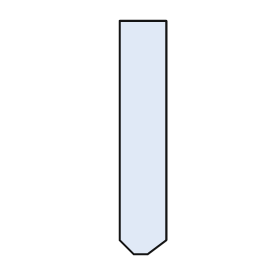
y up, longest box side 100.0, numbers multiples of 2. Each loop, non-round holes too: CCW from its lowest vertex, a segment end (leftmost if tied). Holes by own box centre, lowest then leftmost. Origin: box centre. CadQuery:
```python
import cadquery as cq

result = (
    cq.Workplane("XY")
    .moveTo(-4.0, -50.0)
    .lineTo(2.0, -50.0)
    .lineTo(10.0, -44.0)
    .lineTo(10.0, 50.0)
    .lineTo(-10.0, 50.0)
    .lineTo(-10.0, -44.0)
    .close()
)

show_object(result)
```